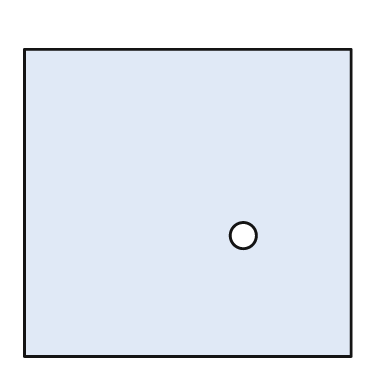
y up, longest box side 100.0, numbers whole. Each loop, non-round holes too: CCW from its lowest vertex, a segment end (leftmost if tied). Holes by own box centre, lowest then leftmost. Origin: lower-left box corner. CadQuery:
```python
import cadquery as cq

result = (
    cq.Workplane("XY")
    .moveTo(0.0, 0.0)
    .lineTo(100.0, 0.0)
    .lineTo(100.0, 94.0)
    .lineTo(0.0, 94.0)
    .close()
    .moveTo(67.0, 37.0)
    .circle(4.0)
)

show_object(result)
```